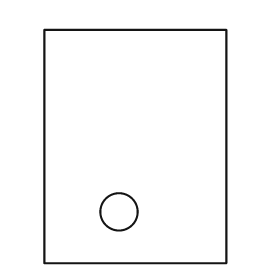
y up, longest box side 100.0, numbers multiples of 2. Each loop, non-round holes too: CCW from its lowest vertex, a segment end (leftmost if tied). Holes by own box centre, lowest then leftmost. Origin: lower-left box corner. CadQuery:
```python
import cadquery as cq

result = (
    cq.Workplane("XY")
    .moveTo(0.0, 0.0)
    .lineTo(78.0, 0.0)
    .lineTo(78.0, 100.0)
    .lineTo(0.0, 100.0)
    .close()
    .moveTo(32.0, 22.0)
    .circle(8.0)
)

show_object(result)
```